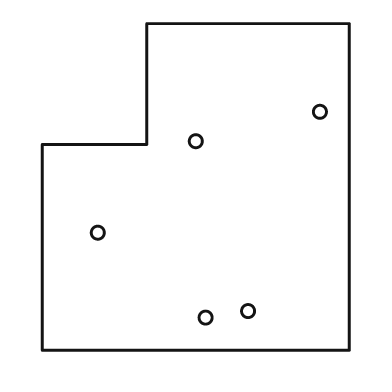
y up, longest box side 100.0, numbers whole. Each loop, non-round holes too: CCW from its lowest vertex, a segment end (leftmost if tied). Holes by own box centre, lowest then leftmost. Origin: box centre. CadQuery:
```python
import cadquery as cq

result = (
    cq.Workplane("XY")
    .moveTo(-47.0, -50.0)
    .lineTo(47.0, -50.0)
    .lineTo(47.0, 50.0)
    .lineTo(-15.0, 50.0)
    .lineTo(-15.0, 13.0)
    .lineTo(-47.0, 13.0)
    .close()
    .moveTo(3.0, -40.0)
    .circle(2.0)
    .moveTo(16.0, -38.0)
    .circle(2.0)
    .moveTo(-30.0, -14.0)
    .circle(2.0)
    .moveTo(0.0, 14.0)
    .circle(2.0)
    .moveTo(38.0, 23.0)
    .circle(2.0)
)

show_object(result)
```